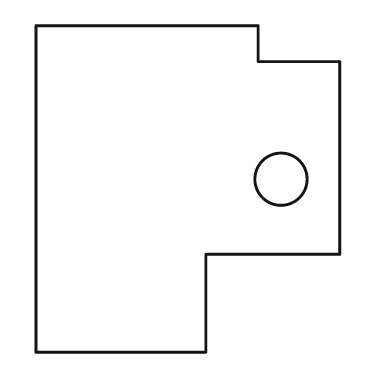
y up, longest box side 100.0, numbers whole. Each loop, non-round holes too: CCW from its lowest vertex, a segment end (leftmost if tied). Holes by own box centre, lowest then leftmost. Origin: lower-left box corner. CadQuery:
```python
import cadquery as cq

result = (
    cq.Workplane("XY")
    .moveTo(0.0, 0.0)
    .lineTo(52.0, 0.0)
    .lineTo(52.0, 30.0)
    .lineTo(93.0, 30.0)
    .lineTo(93.0, 89.0)
    .lineTo(68.0, 89.0)
    .lineTo(68.0, 100.0)
    .lineTo(0.0, 100.0)
    .close()
    .moveTo(75.0, 53.0)
    .circle(8.0)
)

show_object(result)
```